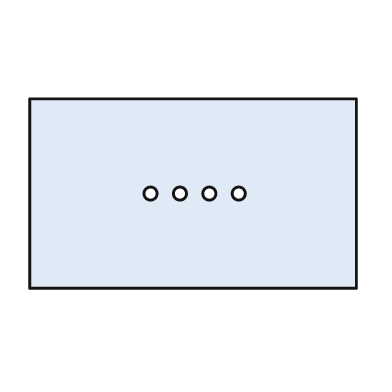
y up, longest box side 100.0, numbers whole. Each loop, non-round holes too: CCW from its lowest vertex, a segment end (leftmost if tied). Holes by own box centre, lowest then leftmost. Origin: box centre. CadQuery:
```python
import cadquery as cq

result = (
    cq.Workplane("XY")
    .moveTo(-50.0, -29.0)
    .lineTo(50.0, -29.0)
    .lineTo(50.0, 29.0)
    .lineTo(-50.0, 29.0)
    .close()
    .moveTo(-13.0, 0.0)
    .circle(2.0)
    .moveTo(-4.0, 0.0)
    .circle(2.0)
    .moveTo(5.0, 0.0)
    .circle(2.0)
    .moveTo(14.0, 0.0)
    .circle(2.0)
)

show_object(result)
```